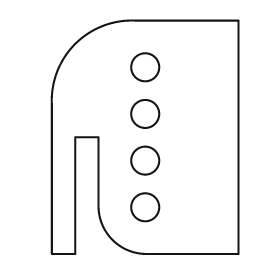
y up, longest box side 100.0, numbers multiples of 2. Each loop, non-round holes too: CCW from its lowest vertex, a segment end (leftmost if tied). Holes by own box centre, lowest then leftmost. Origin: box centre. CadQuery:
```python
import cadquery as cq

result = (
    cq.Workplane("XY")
    .moveTo(-40.0, -50.0)
    .lineTo(-30.0, -50.0)
    .lineTo(-30.0, 0.0)
    .lineTo(-20.0, 0.0)
    .lineTo(-20.0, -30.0)
    .threePointArc((-14.0, -44.0), (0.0, -50.0))
    .lineTo(40.0, -50.0)
    .lineTo(40.0, 50.0)
    .lineTo(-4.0, 50.0)
    .threePointArc((-30.0, 40.0), (-40.0, 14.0))
    .close()
    .moveTo(0.0, -30.0)
    .circle(6.0)
    .moveTo(0.0, -10.0)
    .circle(6.0)
    .moveTo(0.0, 10.0)
    .circle(6.0)
    .moveTo(0.0, 30.0)
    .circle(6.0)
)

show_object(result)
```